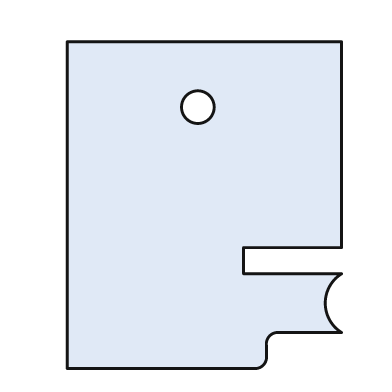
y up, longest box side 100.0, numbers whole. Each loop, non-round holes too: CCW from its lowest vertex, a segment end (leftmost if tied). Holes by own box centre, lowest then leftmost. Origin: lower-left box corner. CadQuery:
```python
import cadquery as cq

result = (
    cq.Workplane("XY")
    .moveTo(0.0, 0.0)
    .lineTo(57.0, 0.0)
    .threePointArc((60.0, 1.0), (61.0, 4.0))
    .lineTo(61.0, 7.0)
    .threePointArc((62.0, 10.0), (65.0, 11.0))
    .lineTo(84.0, 11.0)
    .threePointArc((79.0, 20.0), (84.0, 29.0))
    .lineTo(54.0, 29.0)
    .lineTo(54.0, 37.0)
    .lineTo(84.0, 37.0)
    .lineTo(84.0, 100.0)
    .lineTo(0.0, 100.0)
    .close()
    .moveTo(40.0, 80.0)
    .circle(5.0)
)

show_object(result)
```